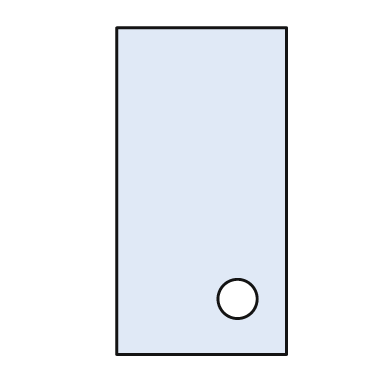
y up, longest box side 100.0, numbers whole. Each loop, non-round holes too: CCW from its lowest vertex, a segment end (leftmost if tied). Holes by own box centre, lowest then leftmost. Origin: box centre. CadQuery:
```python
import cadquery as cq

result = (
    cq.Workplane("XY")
    .moveTo(-26.0, -50.0)
    .lineTo(26.0, -50.0)
    .lineTo(26.0, 50.0)
    .lineTo(-26.0, 50.0)
    .close()
    .moveTo(11.0, -33.0)
    .circle(6.0)
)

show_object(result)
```